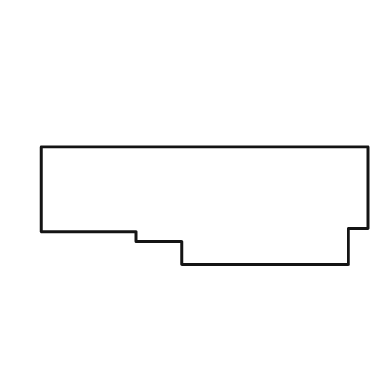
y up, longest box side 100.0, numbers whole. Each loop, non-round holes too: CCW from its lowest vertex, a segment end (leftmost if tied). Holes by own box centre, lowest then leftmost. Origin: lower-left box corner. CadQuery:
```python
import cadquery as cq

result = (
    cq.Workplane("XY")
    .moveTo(43.0, 0.0)
    .lineTo(94.0, 0.0)
    .lineTo(94.0, 11.0)
    .lineTo(100.0, 11.0)
    .lineTo(100.0, 36.0)
    .lineTo(0.0, 36.0)
    .lineTo(0.0, 10.0)
    .lineTo(29.0, 10.0)
    .lineTo(29.0, 7.0)
    .lineTo(43.0, 7.0)
    .close()
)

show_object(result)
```